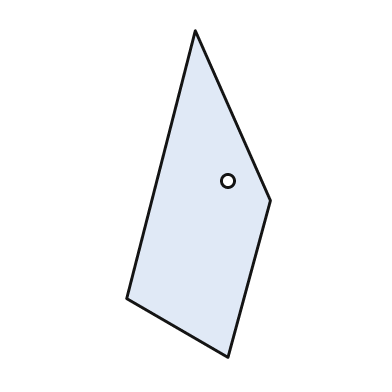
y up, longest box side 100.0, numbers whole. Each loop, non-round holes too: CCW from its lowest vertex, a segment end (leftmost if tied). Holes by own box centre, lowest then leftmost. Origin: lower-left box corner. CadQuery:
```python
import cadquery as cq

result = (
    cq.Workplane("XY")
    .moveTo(31.0, 0.0)
    .lineTo(44.0, 48.0)
    .lineTo(21.0, 100.0)
    .lineTo(0.0, 18.0)
    .close()
    .moveTo(31.0, 54.0)
    .circle(2.0)
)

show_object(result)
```